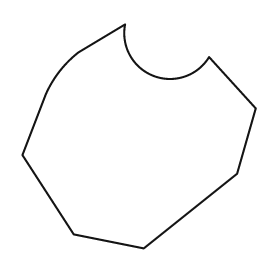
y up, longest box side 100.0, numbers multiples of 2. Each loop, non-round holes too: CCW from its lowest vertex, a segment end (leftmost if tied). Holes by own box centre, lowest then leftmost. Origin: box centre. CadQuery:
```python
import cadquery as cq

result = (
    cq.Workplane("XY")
    .moveTo(2.0, -48.0)
    .lineTo(42.0, -16.0)
    .lineTo(50.0, 12.0)
    .lineTo(30.0, 34.0)
    .threePointArc((6.0, 26.0), (-6.0, 48.0))
    .lineTo(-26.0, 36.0)
    .threePointArc((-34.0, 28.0), (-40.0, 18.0))
    .lineTo(-50.0, -8.0)
    .lineTo(-28.0, -42.0)
    .close()
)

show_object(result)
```